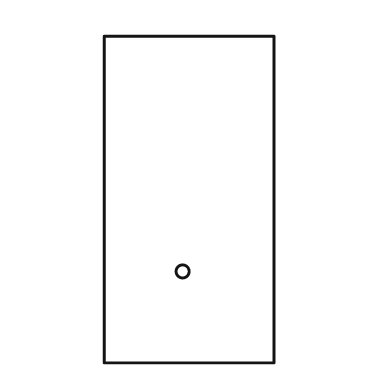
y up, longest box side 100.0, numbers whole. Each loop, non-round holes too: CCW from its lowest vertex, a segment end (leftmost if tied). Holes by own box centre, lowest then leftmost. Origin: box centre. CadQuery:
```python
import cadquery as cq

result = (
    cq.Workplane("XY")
    .moveTo(-26.0, -50.0)
    .lineTo(26.0, -50.0)
    .lineTo(26.0, 50.0)
    .lineTo(-26.0, 50.0)
    .close()
    .moveTo(-2.0, -22.0)
    .circle(2.0)
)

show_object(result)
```